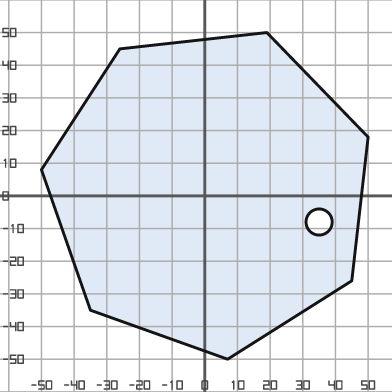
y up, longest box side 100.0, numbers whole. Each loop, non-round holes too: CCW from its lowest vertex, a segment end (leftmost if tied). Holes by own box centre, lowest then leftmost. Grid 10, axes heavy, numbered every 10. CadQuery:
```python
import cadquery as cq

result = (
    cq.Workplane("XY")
    .moveTo(7.0, -50.0)
    .lineTo(45.0, -26.0)
    .lineTo(50.0, 18.0)
    .lineTo(19.0, 50.0)
    .lineTo(-26.0, 45.0)
    .lineTo(-50.0, 8.0)
    .lineTo(-35.0, -35.0)
    .close()
    .moveTo(35.0, -8.0)
    .circle(4.0)
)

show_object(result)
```